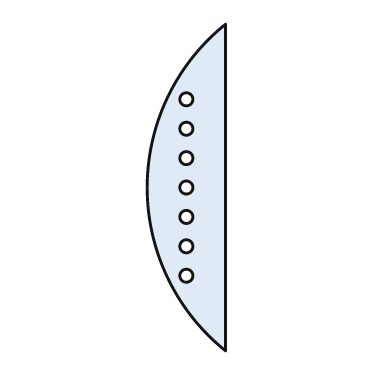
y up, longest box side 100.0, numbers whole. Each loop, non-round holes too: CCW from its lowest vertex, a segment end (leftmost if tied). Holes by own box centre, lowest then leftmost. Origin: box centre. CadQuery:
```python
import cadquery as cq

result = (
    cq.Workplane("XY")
    .moveTo(12.0, -50.0)
    .lineTo(12.0, 50.0)
    .threePointArc((-12.0, 0.0), (12.0, -50.0))
    .close()
    .moveTo(0.0, -27.0)
    .circle(2.0)
    .moveTo(0.0, -18.0)
    .circle(2.0)
    .moveTo(0.0, -9.0)
    .circle(2.0)
    .moveTo(0.0, 0.0)
    .circle(2.0)
    .moveTo(0.0, 9.0)
    .circle(2.0)
    .moveTo(0.0, 18.0)
    .circle(2.0)
    .moveTo(0.0, 27.0)
    .circle(2.0)
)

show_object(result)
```